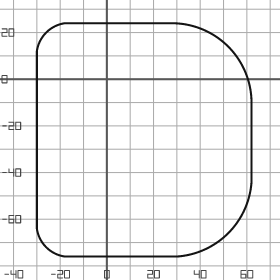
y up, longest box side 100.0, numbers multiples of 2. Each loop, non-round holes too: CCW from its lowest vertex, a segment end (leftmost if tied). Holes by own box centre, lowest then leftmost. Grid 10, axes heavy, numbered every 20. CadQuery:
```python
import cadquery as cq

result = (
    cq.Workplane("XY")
    .moveTo(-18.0, -76.0)
    .lineTo(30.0, -76.0)
    .threePointArc((52.0, -66.0), (62.0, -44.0))
    .lineTo(62.0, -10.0)
    .threePointArc((52.0, 14.0), (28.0, 24.0))
    .lineTo(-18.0, 24.0)
    .threePointArc((-26.0, 20.0), (-30.0, 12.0))
    .lineTo(-30.0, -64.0)
    .threePointArc((-26.0, -72.0), (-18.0, -76.0))
    .close()
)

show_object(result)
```